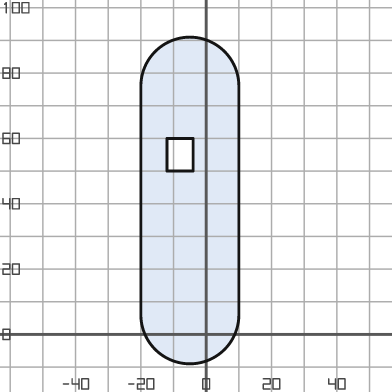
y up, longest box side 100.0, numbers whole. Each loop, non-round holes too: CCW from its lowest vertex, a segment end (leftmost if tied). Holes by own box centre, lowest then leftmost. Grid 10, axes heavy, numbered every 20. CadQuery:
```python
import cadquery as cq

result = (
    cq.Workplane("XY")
    .moveTo(-20.0, 6.0)
    .threePointArc((-5.0, -9.0), (10.0, 6.0))
    .lineTo(10.0, 76.0)
    .threePointArc((-5.0, 91.0), (-20.0, 76.0))
    .close()
    .moveTo(-12.0, 50.0)
    .lineTo(-4.0, 50.0)
    .lineTo(-4.0, 60.0)
    .lineTo(-12.0, 60.0)
    .close()
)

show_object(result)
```